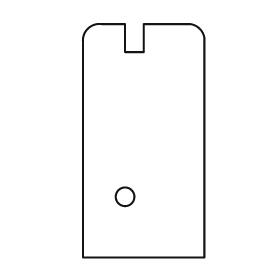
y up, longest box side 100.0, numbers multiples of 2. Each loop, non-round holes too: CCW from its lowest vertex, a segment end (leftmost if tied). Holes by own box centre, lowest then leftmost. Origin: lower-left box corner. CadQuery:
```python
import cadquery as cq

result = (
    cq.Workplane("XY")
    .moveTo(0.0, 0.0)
    .lineTo(52.0, 0.0)
    .lineTo(52.0, 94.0)
    .threePointArc((50.0, 98.0), (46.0, 100.0))
    .lineTo(26.0, 100.0)
    .lineTo(26.0, 88.0)
    .lineTo(18.0, 88.0)
    .lineTo(18.0, 100.0)
    .lineTo(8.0, 100.0)
    .threePointArc((2.0, 98.0), (0.0, 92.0))
    .close()
    .moveTo(18.0, 26.0)
    .circle(4.0)
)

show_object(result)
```